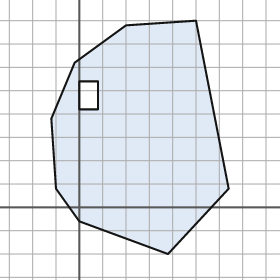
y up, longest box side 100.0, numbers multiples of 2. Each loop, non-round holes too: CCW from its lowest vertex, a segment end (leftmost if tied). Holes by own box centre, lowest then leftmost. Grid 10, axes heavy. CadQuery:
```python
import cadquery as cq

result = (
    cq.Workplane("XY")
    .moveTo(38.0, -20.0)
    .lineTo(64.0, 8.0)
    .lineTo(50.0, 80.0)
    .lineTo(20.0, 78.0)
    .lineTo(-2.0, 62.0)
    .lineTo(-12.0, 38.0)
    .lineTo(-10.0, 8.0)
    .lineTo(0.0, -6.0)
    .close()
    .moveTo(0.0, 42.0)
    .lineTo(8.0, 42.0)
    .lineTo(8.0, 54.0)
    .lineTo(0.0, 54.0)
    .close()
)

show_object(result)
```